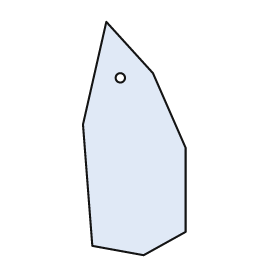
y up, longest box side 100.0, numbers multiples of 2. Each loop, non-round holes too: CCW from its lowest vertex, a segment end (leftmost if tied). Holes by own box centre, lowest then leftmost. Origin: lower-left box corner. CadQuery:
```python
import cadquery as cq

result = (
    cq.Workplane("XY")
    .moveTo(26.0, 0.0)
    .lineTo(44.0, 10.0)
    .lineTo(44.0, 46.0)
    .lineTo(30.0, 78.0)
    .lineTo(10.0, 100.0)
    .lineTo(0.0, 56.0)
    .lineTo(4.0, 4.0)
    .close()
    .moveTo(16.0, 76.0)
    .circle(2.0)
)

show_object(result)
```